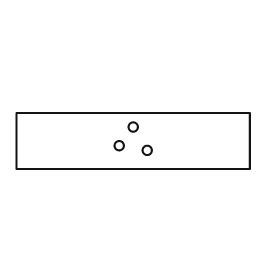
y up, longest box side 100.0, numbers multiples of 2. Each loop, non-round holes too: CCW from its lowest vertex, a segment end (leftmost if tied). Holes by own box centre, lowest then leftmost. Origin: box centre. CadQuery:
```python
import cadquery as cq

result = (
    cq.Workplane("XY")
    .moveTo(-50.0, -12.0)
    .lineTo(50.0, -12.0)
    .lineTo(50.0, 12.0)
    .lineTo(-50.0, 12.0)
    .close()
    .moveTo(6.0, -4.0)
    .circle(2.0)
    .moveTo(-6.0, -2.0)
    .circle(2.0)
    .moveTo(0.0, 6.0)
    .circle(2.0)
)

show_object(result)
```